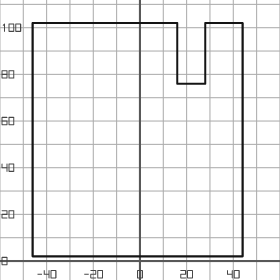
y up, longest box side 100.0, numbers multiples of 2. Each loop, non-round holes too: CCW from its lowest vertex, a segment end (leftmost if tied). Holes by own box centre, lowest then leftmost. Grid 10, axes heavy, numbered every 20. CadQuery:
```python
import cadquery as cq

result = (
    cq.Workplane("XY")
    .moveTo(-46.0, 2.0)
    .lineTo(44.0, 2.0)
    .lineTo(44.0, 102.0)
    .lineTo(28.0, 102.0)
    .lineTo(28.0, 76.0)
    .lineTo(16.0, 76.0)
    .lineTo(16.0, 102.0)
    .lineTo(-46.0, 102.0)
    .close()
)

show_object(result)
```